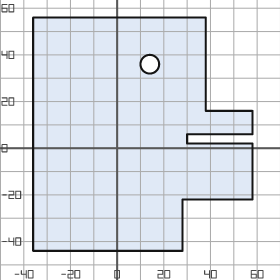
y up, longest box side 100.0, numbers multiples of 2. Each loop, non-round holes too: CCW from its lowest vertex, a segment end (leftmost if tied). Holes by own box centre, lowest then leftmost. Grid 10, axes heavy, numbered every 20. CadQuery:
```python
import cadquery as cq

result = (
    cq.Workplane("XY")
    .moveTo(-36.0, -44.0)
    .lineTo(28.0, -44.0)
    .lineTo(28.0, -22.0)
    .lineTo(58.0, -22.0)
    .lineTo(58.0, 2.0)
    .lineTo(30.0, 2.0)
    .lineTo(30.0, 6.0)
    .lineTo(58.0, 6.0)
    .lineTo(58.0, 16.0)
    .lineTo(38.0, 16.0)
    .lineTo(38.0, 56.0)
    .lineTo(-36.0, 56.0)
    .close()
    .moveTo(14.0, 36.0)
    .circle(4.0)
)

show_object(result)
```